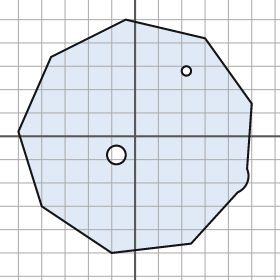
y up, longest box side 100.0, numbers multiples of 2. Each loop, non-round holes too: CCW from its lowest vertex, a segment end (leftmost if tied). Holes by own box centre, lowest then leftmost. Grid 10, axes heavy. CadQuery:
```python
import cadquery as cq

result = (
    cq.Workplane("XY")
    .moveTo(-10.0, -50.0)
    .lineTo(24.0, -46.0)
    .lineTo(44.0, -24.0)
    .threePointArc((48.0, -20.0), (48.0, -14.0))
    .lineTo(50.0, 14.0)
    .lineTo(30.0, 42.0)
    .lineTo(-4.0, 50.0)
    .lineTo(-36.0, 34.0)
    .lineTo(-50.0, 2.0)
    .lineTo(-40.0, -30.0)
    .close()
    .moveTo(-8.0, -8.0)
    .circle(4.0)
    .moveTo(22.0, 28.0)
    .circle(2.0)
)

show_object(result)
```